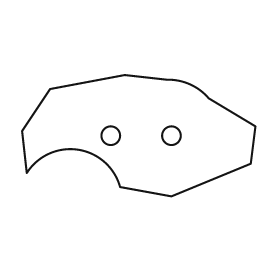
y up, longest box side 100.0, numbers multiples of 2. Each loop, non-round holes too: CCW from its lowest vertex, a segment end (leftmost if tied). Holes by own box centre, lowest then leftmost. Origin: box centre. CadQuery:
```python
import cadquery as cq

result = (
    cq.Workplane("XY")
    .moveTo(14.0, -26.0)
    .lineTo(48.0, -12.0)
    .lineTo(50.0, 4.0)
    .lineTo(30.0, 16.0)
    .threePointArc((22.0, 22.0), (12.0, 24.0))
    .lineTo(-6.0, 26.0)
    .lineTo(-38.0, 20.0)
    .lineTo(-50.0, 2.0)
    .lineTo(-48.0, -16.0)
    .threePointArc((-26.0, -6.0), (-8.0, -22.0))
    .close()
    .moveTo(-12.0, 0.0)
    .circle(4.0)
    .moveTo(14.0, 0.0)
    .circle(4.0)
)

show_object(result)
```